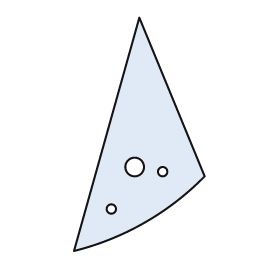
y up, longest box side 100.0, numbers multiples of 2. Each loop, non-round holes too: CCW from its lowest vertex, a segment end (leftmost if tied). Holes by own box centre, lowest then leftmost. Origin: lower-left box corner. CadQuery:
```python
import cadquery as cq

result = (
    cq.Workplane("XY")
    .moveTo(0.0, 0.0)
    .threePointArc((30.0, 12.0), (56.0, 32.0))
    .lineTo(28.0, 100.0)
    .close()
    .moveTo(16.0, 18.0)
    .circle(2.0)
    .moveTo(38.0, 34.0)
    .circle(2.0)
    .moveTo(26.0, 36.0)
    .circle(4.0)
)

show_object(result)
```